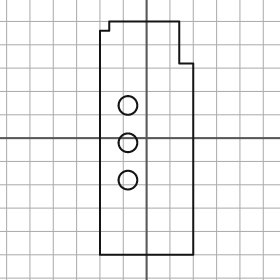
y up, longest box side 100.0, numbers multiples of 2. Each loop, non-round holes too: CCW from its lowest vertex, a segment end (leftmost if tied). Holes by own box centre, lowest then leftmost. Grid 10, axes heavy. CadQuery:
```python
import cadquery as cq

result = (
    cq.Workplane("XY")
    .moveTo(-20.0, -50.0)
    .lineTo(20.0, -50.0)
    .lineTo(20.0, 32.0)
    .lineTo(14.0, 32.0)
    .lineTo(14.0, 50.0)
    .lineTo(-16.0, 50.0)
    .lineTo(-16.0, 46.0)
    .lineTo(-20.0, 46.0)
    .close()
    .moveTo(-8.0, -18.0)
    .circle(4.0)
    .moveTo(-8.0, -2.0)
    .circle(4.0)
    .moveTo(-8.0, 14.0)
    .circle(4.0)
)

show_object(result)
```